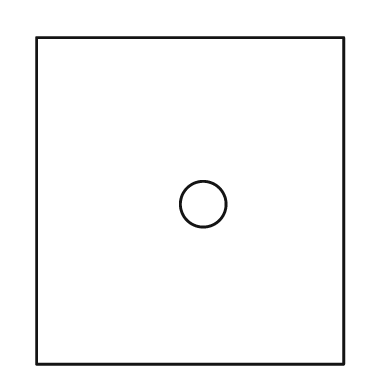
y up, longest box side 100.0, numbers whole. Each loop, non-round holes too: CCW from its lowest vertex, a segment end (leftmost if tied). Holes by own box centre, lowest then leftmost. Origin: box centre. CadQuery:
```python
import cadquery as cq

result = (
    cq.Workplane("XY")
    .moveTo(-47.0, -50.0)
    .lineTo(47.0, -50.0)
    .lineTo(47.0, 50.0)
    .lineTo(-47.0, 50.0)
    .close()
    .moveTo(4.0, -1.0)
    .circle(7.0)
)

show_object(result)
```